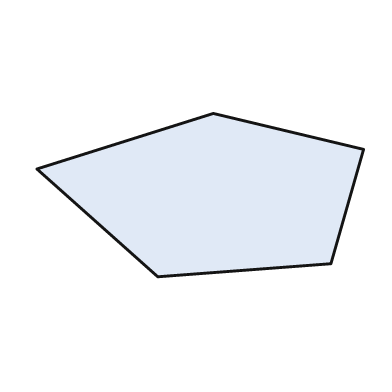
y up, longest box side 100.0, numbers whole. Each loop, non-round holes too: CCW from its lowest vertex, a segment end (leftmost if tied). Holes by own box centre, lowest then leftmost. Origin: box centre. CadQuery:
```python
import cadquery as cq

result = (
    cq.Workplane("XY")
    .moveTo(-13.0, -25.0)
    .lineTo(40.0, -21.0)
    .lineTo(50.0, 14.0)
    .lineTo(4.0, 25.0)
    .lineTo(-50.0, 8.0)
    .close()
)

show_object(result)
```